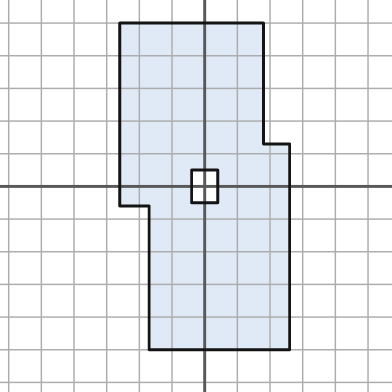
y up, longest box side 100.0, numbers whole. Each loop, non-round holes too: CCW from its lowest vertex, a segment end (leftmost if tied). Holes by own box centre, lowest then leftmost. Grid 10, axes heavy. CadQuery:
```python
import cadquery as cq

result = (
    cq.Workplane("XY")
    .moveTo(-17.0, -50.0)
    .lineTo(26.0, -50.0)
    .lineTo(26.0, 13.0)
    .lineTo(18.0, 13.0)
    .lineTo(18.0, 50.0)
    .lineTo(-26.0, 50.0)
    .lineTo(-26.0, -6.0)
    .lineTo(-17.0, -6.0)
    .close()
    .moveTo(-4.0, -5.0)
    .lineTo(4.0, -5.0)
    .lineTo(4.0, 5.0)
    .lineTo(-4.0, 5.0)
    .close()
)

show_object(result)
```